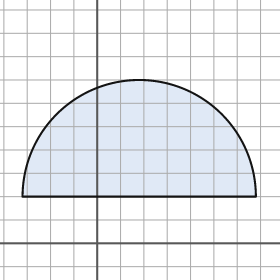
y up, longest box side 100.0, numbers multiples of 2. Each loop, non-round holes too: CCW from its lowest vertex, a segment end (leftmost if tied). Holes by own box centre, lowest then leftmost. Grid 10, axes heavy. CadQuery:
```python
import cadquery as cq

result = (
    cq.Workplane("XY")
    .moveTo(-32.0, 20.0)
    .lineTo(68.0, 20.0)
    .threePointArc((18.0, 70.0), (-32.0, 20.0))
    .close()
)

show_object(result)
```